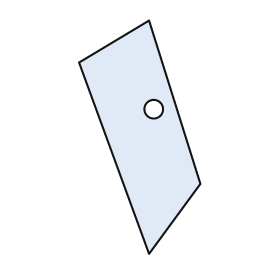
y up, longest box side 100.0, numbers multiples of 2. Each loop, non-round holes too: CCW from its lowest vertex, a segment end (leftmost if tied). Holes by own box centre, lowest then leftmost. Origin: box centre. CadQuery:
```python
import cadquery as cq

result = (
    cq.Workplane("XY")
    .moveTo(4.0, -50.0)
    .lineTo(26.0, -20.0)
    .lineTo(4.0, 50.0)
    .lineTo(-26.0, 32.0)
    .close()
    .moveTo(6.0, 12.0)
    .circle(4.0)
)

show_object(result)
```